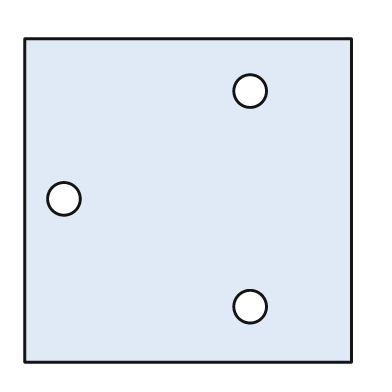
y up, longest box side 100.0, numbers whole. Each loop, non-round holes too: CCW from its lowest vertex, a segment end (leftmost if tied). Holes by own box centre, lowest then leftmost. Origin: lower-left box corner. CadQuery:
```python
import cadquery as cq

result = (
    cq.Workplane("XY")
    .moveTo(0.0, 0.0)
    .lineTo(100.0, 0.0)
    .lineTo(100.0, 99.0)
    .lineTo(0.0, 99.0)
    .close()
    .moveTo(69.0, 17.0)
    .circle(5.0)
    .moveTo(12.0, 50.0)
    .circle(5.0)
    .moveTo(69.0, 83.0)
    .circle(5.0)
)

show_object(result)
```